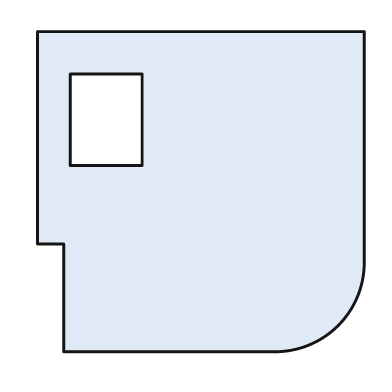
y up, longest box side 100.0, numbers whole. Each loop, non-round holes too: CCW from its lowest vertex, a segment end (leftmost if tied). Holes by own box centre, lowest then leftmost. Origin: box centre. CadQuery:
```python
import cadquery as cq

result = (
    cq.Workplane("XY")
    .moveTo(-42.0, -49.0)
    .lineTo(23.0, -49.0)
    .threePointArc((42.0, -41.0), (50.0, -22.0))
    .lineTo(50.0, 49.0)
    .lineTo(-50.0, 49.0)
    .lineTo(-50.0, -16.0)
    .lineTo(-42.0, -16.0)
    .close()
    .moveTo(-40.0, 8.0)
    .lineTo(-18.0, 8.0)
    .lineTo(-18.0, 36.0)
    .lineTo(-40.0, 36.0)
    .close()
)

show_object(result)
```